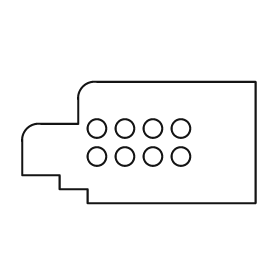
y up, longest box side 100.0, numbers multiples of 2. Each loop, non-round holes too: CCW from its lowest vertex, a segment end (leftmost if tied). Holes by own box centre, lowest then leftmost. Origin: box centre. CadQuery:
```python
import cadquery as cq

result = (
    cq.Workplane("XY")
    .moveTo(-22.0, -26.0)
    .lineTo(50.0, -26.0)
    .lineTo(50.0, 26.0)
    .lineTo(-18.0, 26.0)
    .threePointArc((-24.0, 24.0), (-26.0, 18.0))
    .lineTo(-26.0, 8.0)
    .lineTo(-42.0, 8.0)
    .threePointArc((-48.0, 6.0), (-50.0, 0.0))
    .lineTo(-50.0, -14.0)
    .lineTo(-34.0, -14.0)
    .lineTo(-34.0, -20.0)
    .lineTo(-22.0, -20.0)
    .close()
    .moveTo(-18.0, -6.0)
    .circle(4.0)
    .moveTo(-6.0, -6.0)
    .circle(4.0)
    .moveTo(6.0, -6.0)
    .circle(4.0)
    .moveTo(18.0, -6.0)
    .circle(4.0)
    .moveTo(-18.0, 6.0)
    .circle(4.0)
    .moveTo(-6.0, 6.0)
    .circle(4.0)
    .moveTo(6.0, 6.0)
    .circle(4.0)
    .moveTo(18.0, 6.0)
    .circle(4.0)
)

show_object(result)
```